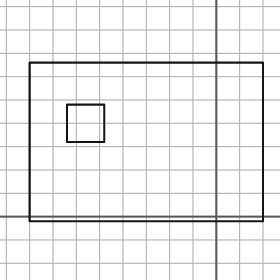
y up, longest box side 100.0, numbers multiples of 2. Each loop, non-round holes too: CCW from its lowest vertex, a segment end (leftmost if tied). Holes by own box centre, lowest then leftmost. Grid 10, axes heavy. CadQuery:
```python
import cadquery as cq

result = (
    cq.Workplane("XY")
    .moveTo(-80.0, -2.0)
    .lineTo(20.0, -2.0)
    .lineTo(20.0, 66.0)
    .lineTo(-80.0, 66.0)
    .close()
    .moveTo(-64.0, 32.0)
    .lineTo(-48.0, 32.0)
    .lineTo(-48.0, 48.0)
    .lineTo(-64.0, 48.0)
    .close()
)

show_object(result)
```